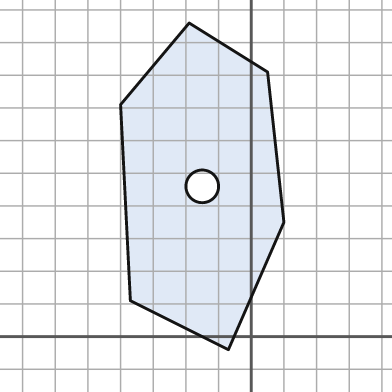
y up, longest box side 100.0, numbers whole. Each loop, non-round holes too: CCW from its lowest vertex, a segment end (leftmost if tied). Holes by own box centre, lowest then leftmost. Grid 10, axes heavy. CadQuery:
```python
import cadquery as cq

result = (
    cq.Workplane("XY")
    .moveTo(-7.0, -4.0)
    .lineTo(10.0, 35.0)
    .lineTo(5.0, 81.0)
    .lineTo(-19.0, 96.0)
    .lineTo(-40.0, 71.0)
    .lineTo(-37.0, 11.0)
    .close()
    .moveTo(-15.0, 46.0)
    .circle(5.0)
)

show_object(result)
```